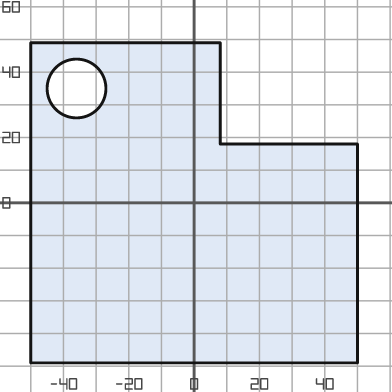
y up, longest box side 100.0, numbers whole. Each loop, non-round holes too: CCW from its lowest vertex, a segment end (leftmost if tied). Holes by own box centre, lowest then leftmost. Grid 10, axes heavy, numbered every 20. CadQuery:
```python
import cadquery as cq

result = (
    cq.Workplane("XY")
    .moveTo(-50.0, -49.0)
    .lineTo(50.0, -49.0)
    .lineTo(50.0, 18.0)
    .lineTo(8.0, 18.0)
    .lineTo(8.0, 49.0)
    .lineTo(-50.0, 49.0)
    .close()
    .moveTo(-36.0, 35.0)
    .circle(9.0)
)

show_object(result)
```